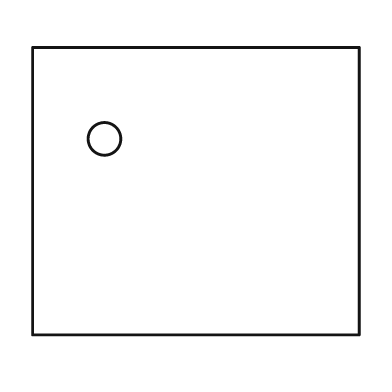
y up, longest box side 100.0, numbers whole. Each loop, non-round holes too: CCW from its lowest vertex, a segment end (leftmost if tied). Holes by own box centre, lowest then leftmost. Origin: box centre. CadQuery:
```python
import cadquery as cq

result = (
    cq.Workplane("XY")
    .moveTo(-50.0, -44.0)
    .lineTo(50.0, -44.0)
    .lineTo(50.0, 44.0)
    .lineTo(-50.0, 44.0)
    .close()
    .moveTo(-28.0, 16.0)
    .circle(5.0)
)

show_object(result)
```